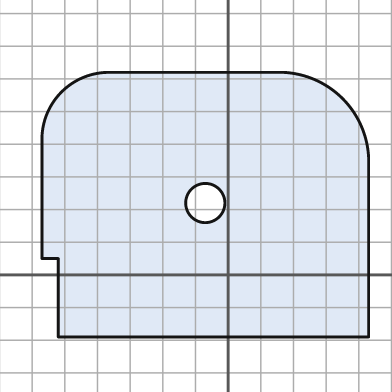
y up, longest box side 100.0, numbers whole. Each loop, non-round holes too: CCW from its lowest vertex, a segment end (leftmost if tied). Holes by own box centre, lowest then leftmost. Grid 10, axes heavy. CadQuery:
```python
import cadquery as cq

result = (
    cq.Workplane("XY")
    .moveTo(-52.0, -19.0)
    .lineTo(43.0, -19.0)
    .lineTo(43.0, 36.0)
    .threePointArc((35.0, 54.0), (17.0, 62.0))
    .lineTo(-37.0, 62.0)
    .threePointArc((-51.0, 56.0), (-57.0, 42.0))
    .lineTo(-57.0, 5.0)
    .lineTo(-52.0, 5.0)
    .close()
    .moveTo(-7.0, 22.0)
    .circle(6.0)
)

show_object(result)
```